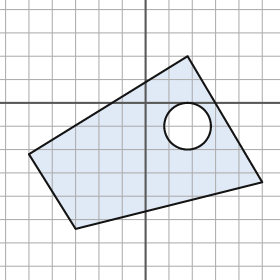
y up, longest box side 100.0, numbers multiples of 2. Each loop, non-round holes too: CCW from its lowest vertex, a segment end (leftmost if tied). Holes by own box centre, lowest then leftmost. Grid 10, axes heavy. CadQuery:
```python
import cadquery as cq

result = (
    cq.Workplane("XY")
    .moveTo(-30.0, -54.0)
    .lineTo(50.0, -34.0)
    .lineTo(18.0, 20.0)
    .lineTo(-50.0, -22.0)
    .close()
    .moveTo(18.0, -10.0)
    .circle(10.0)
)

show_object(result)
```